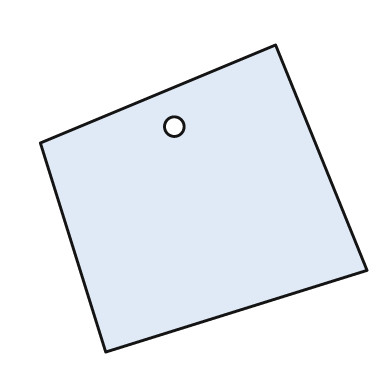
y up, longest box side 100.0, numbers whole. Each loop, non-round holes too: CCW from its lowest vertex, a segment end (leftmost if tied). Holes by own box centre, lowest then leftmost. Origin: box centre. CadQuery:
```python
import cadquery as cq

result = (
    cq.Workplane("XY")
    .moveTo(-30.0, -47.0)
    .lineTo(50.0, -22.0)
    .lineTo(22.0, 47.0)
    .lineTo(-50.0, 17.0)
    .close()
    .moveTo(-9.0, 22.0)
    .circle(3.0)
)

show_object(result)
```